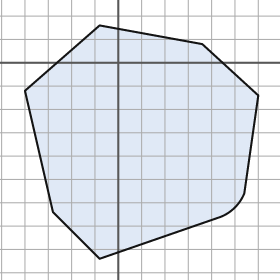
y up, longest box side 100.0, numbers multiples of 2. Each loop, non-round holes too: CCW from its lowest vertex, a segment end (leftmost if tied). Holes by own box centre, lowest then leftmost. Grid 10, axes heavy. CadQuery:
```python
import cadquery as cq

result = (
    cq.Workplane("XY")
    .moveTo(-8.0, -84.0)
    .lineTo(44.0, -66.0)
    .threePointArc((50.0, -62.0), (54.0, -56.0))
    .lineTo(60.0, -14.0)
    .lineTo(36.0, 8.0)
    .lineTo(-8.0, 16.0)
    .lineTo(-40.0, -12.0)
    .lineTo(-28.0, -64.0)
    .close()
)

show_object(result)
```